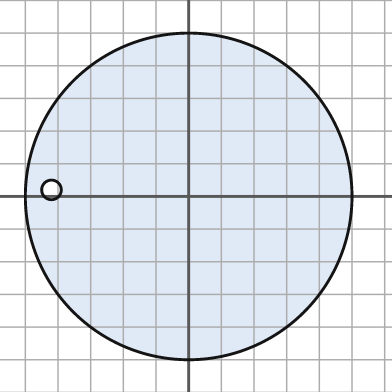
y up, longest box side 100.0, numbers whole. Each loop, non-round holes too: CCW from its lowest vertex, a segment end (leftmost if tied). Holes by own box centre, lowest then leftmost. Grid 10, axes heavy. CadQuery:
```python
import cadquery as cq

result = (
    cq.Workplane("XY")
    .moveTo(0.0, 0.0)
    .circle(50.0)
    .moveTo(-42.0, 2.0)
    .circle(3.0)
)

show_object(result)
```